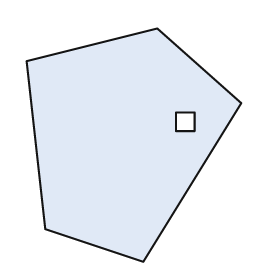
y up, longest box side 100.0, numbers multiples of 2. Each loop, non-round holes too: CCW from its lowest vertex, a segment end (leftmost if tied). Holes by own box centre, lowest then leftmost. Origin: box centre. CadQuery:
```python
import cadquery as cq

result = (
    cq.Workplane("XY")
    .moveTo(4.0, -50.0)
    .lineTo(46.0, 18.0)
    .lineTo(10.0, 50.0)
    .lineTo(-46.0, 36.0)
    .lineTo(-38.0, -36.0)
    .close()
    .moveTo(18.0, 6.0)
    .lineTo(26.0, 6.0)
    .lineTo(26.0, 14.0)
    .lineTo(18.0, 14.0)
    .close()
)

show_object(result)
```